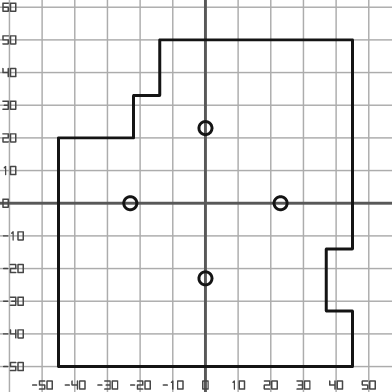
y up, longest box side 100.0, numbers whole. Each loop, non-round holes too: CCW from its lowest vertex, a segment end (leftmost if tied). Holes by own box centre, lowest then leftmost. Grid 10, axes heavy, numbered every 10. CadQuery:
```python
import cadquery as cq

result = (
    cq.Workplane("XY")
    .moveTo(-45.0, -50.0)
    .lineTo(45.0, -50.0)
    .lineTo(45.0, -33.0)
    .lineTo(37.0, -33.0)
    .lineTo(37.0, -14.0)
    .lineTo(45.0, -14.0)
    .lineTo(45.0, 50.0)
    .lineTo(-14.0, 50.0)
    .lineTo(-14.0, 33.0)
    .lineTo(-22.0, 33.0)
    .lineTo(-22.0, 20.0)
    .lineTo(-45.0, 20.0)
    .close()
    .moveTo(0.0, -23.0)
    .circle(2.0)
    .moveTo(-23.0, 0.0)
    .circle(2.0)
    .moveTo(23.0, 0.0)
    .circle(2.0)
    .moveTo(0.0, 23.0)
    .circle(2.0)
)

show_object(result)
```